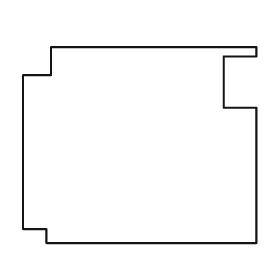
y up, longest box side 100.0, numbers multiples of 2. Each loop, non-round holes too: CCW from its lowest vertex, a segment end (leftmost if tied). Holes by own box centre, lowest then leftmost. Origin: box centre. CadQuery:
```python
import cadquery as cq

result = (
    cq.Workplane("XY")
    .moveTo(-40.0, -42.0)
    .lineTo(50.0, -42.0)
    .lineTo(50.0, 16.0)
    .lineTo(36.0, 16.0)
    .lineTo(36.0, 38.0)
    .lineTo(50.0, 38.0)
    .lineTo(50.0, 42.0)
    .lineTo(-38.0, 42.0)
    .lineTo(-38.0, 30.0)
    .lineTo(-50.0, 30.0)
    .lineTo(-50.0, -36.0)
    .lineTo(-40.0, -36.0)
    .close()
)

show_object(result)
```